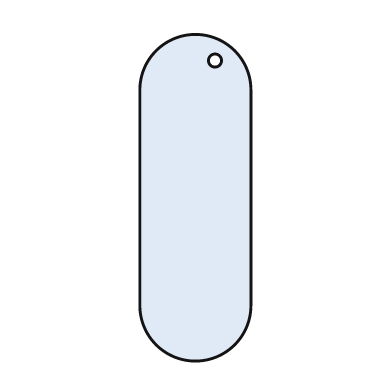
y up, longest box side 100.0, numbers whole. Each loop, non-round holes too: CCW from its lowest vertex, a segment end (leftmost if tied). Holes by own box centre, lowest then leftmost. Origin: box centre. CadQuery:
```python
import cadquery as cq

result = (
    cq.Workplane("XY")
    .moveTo(-17.0, -33.0)
    .threePointArc((0.0, -50.0), (17.0, -33.0))
    .lineTo(17.0, 33.0)
    .threePointArc((0.0, 50.0), (-17.0, 33.0))
    .close()
    .moveTo(6.0, 42.0)
    .circle(2.0)
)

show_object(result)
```